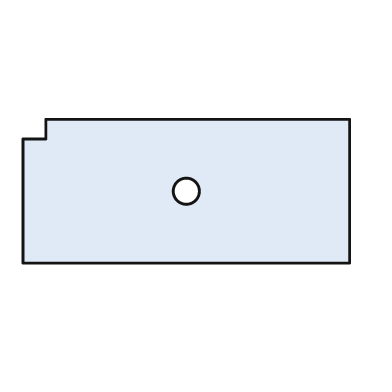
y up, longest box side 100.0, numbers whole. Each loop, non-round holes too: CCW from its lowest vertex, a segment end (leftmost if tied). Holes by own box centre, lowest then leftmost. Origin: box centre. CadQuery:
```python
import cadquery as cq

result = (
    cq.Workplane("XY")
    .moveTo(-50.0, -22.0)
    .lineTo(50.0, -22.0)
    .lineTo(50.0, 22.0)
    .lineTo(-43.0, 22.0)
    .lineTo(-43.0, 16.0)
    .lineTo(-50.0, 16.0)
    .close()
    .moveTo(0.0, 0.0)
    .circle(4.0)
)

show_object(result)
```